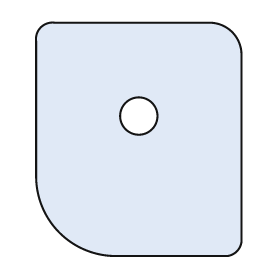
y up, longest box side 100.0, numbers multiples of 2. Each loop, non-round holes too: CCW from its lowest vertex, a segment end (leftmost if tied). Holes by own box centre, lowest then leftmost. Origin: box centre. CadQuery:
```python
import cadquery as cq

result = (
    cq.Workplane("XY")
    .moveTo(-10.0, -50.0)
    .lineTo(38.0, -50.0)
    .threePointArc((42.0, -48.0), (44.0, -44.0))
    .lineTo(44.0, 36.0)
    .threePointArc((40.0, 46.0), (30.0, 50.0))
    .lineTo(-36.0, 50.0)
    .threePointArc((-42.0, 48.0), (-44.0, 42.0))
    .lineTo(-44.0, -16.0)
    .threePointArc((-34.0, -40.0), (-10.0, -50.0))
    .close()
    .moveTo(0.0, 10.0)
    .circle(8.0)
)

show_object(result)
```